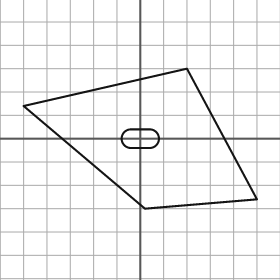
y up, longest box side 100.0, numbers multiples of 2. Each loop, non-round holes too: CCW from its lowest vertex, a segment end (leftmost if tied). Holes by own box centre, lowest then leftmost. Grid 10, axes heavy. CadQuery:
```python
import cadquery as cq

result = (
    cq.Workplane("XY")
    .moveTo(2.0, -30.0)
    .lineTo(50.0, -26.0)
    .lineTo(20.0, 30.0)
    .lineTo(-50.0, 14.0)
    .close()
    .moveTo(-4.0, -4.0)
    .lineTo(4.0, -4.0)
    .threePointArc((8.0, 0.0), (4.0, 4.0))
    .lineTo(-4.0, 4.0)
    .threePointArc((-8.0, 0.0), (-4.0, -4.0))
    .close()
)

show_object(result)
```